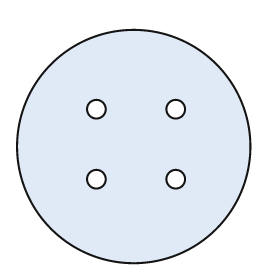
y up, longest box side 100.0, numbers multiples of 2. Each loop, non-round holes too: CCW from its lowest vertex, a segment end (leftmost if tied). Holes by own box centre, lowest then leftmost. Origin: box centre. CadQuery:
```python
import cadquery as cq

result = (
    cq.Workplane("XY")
    .moveTo(0.0, 0.0)
    .circle(50.0)
    .moveTo(-16.0, -14.0)
    .circle(4.0)
    .moveTo(18.0, -14.0)
    .circle(4.0)
    .moveTo(-16.0, 16.0)
    .circle(4.0)
    .moveTo(18.0, 16.0)
    .circle(4.0)
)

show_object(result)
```